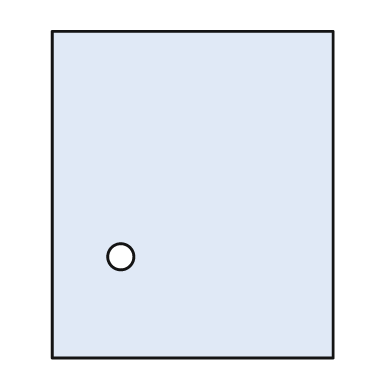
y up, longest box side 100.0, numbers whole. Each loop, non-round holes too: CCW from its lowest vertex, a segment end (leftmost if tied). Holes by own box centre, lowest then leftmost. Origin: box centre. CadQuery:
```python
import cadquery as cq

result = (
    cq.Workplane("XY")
    .moveTo(-43.0, -50.0)
    .lineTo(43.0, -50.0)
    .lineTo(43.0, 50.0)
    .lineTo(-43.0, 50.0)
    .close()
    .moveTo(-22.0, -19.0)
    .circle(4.0)
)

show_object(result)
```